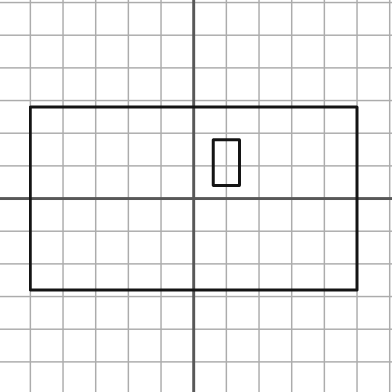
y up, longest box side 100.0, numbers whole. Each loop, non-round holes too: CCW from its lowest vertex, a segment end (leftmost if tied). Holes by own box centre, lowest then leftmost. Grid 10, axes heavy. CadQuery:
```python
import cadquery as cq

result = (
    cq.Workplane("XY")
    .moveTo(-50.0, -28.0)
    .lineTo(50.0, -28.0)
    .lineTo(50.0, 28.0)
    .lineTo(-50.0, 28.0)
    .close()
    .moveTo(6.0, 4.0)
    .lineTo(14.0, 4.0)
    .lineTo(14.0, 18.0)
    .lineTo(6.0, 18.0)
    .close()
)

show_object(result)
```